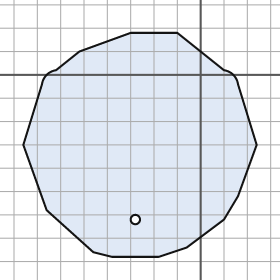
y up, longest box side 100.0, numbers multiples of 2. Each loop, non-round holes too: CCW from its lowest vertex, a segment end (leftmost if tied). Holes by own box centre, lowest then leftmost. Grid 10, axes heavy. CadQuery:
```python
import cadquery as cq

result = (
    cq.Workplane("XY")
    .moveTo(-38.0, -78.0)
    .lineTo(-18.0, -78.0)
    .lineTo(-6.0, -74.0)
    .lineTo(10.0, -62.0)
    .lineTo(16.0, -52.0)
    .lineTo(24.0, -30.0)
    .lineTo(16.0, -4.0)
    .threePointArc((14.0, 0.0), (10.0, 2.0))
    .lineTo(-10.0, 18.0)
    .lineTo(-30.0, 18.0)
    .lineTo(-52.0, 10.0)
    .lineTo(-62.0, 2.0)
    .threePointArc((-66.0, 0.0), (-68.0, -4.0))
    .lineTo(-76.0, -30.0)
    .lineTo(-66.0, -58.0)
    .lineTo(-46.0, -76.0)
    .close()
    .moveTo(-28.0, -62.0)
    .circle(2.0)
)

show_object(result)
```